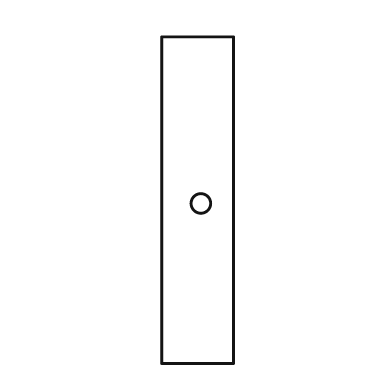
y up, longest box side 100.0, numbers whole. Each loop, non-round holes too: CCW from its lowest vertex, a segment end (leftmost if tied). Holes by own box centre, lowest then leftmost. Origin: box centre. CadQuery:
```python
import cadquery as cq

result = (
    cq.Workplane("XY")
    .moveTo(-11.0, -50.0)
    .lineTo(11.0, -50.0)
    .lineTo(11.0, 50.0)
    .lineTo(-11.0, 50.0)
    .close()
    .moveTo(1.0, -1.0)
    .circle(3.0)
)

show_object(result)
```